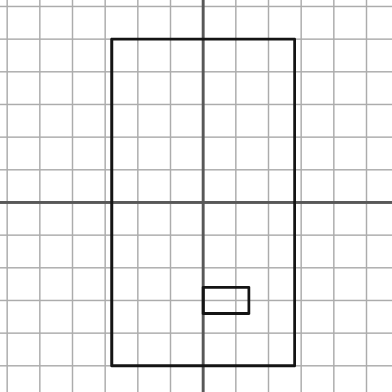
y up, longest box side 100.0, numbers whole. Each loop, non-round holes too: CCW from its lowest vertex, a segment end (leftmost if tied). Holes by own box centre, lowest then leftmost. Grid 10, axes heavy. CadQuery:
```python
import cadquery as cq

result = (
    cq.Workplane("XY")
    .moveTo(-28.0, -50.0)
    .lineTo(28.0, -50.0)
    .lineTo(28.0, 50.0)
    .lineTo(-28.0, 50.0)
    .close()
    .moveTo(0.0, -34.0)
    .lineTo(14.0, -34.0)
    .lineTo(14.0, -26.0)
    .lineTo(0.0, -26.0)
    .close()
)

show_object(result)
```